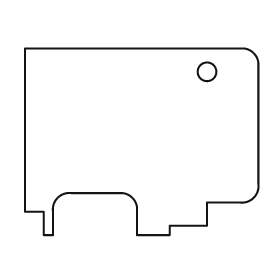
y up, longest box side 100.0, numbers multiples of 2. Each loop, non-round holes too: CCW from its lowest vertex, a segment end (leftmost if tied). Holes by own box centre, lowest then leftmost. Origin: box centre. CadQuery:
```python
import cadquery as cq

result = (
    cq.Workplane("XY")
    .moveTo(-42.0, -40.0)
    .lineTo(-38.0, -40.0)
    .lineTo(-38.0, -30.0)
    .threePointArc((-36.0, -24.0), (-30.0, -22.0))
    .lineTo(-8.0, -22.0)
    .threePointArc((-4.0, -24.0), (-2.0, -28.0))
    .lineTo(-2.0, -40.0)
    .lineTo(12.0, -40.0)
    .lineTo(12.0, -36.0)
    .lineTo(28.0, -36.0)
    .lineTo(28.0, -26.0)
    .lineTo(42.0, -26.0)
    .threePointArc((48.0, -24.0), (50.0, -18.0))
    .lineTo(50.0, 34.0)
    .threePointArc((48.0, 38.0), (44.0, 40.0))
    .lineTo(-50.0, 40.0)
    .lineTo(-50.0, -30.0)
    .lineTo(-42.0, -30.0)
    .close()
    .moveTo(28.0, 30.0)
    .circle(4.0)
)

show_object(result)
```